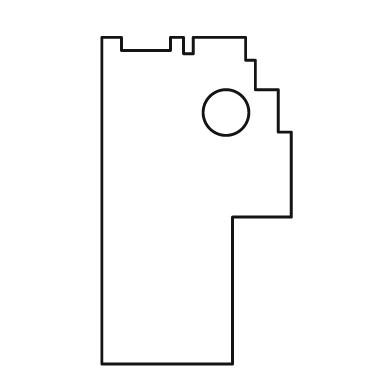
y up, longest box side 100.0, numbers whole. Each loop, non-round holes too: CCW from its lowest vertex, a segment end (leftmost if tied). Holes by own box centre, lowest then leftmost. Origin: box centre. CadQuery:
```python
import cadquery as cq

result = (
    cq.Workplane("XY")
    .moveTo(-29.0, -50.0)
    .lineTo(11.0, -50.0)
    .lineTo(11.0, -5.0)
    .lineTo(29.0, -5.0)
    .lineTo(29.0, 21.0)
    .lineTo(25.0, 21.0)
    .lineTo(25.0, 34.0)
    .lineTo(18.0, 34.0)
    .lineTo(18.0, 43.0)
    .lineTo(15.0, 43.0)
    .lineTo(15.0, 50.0)
    .lineTo(-1.0, 50.0)
    .lineTo(-1.0, 45.0)
    .lineTo(-4.0, 45.0)
    .lineTo(-4.0, 50.0)
    .lineTo(-8.0, 50.0)
    .lineTo(-8.0, 46.0)
    .lineTo(-23.0, 46.0)
    .lineTo(-23.0, 50.0)
    .lineTo(-29.0, 50.0)
    .close()
    .moveTo(9.0, 27.0)
    .circle(7.0)
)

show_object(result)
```